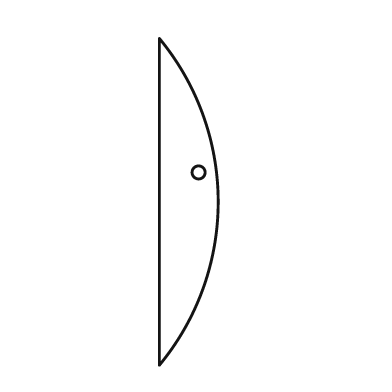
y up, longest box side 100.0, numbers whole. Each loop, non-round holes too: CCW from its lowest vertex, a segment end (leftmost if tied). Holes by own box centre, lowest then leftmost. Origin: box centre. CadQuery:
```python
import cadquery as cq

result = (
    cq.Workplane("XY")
    .moveTo(-9.0, -50.0)
    .threePointArc((9.0, 0.0), (-9.0, 50.0))
    .close()
    .moveTo(3.0, 9.0)
    .circle(2.0)
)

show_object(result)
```